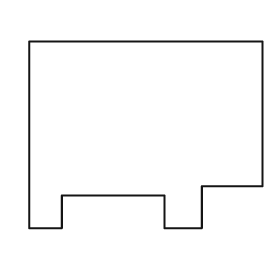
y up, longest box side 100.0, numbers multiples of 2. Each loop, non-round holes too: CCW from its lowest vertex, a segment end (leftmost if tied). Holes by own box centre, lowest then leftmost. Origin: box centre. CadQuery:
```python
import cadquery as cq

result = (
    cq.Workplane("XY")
    .moveTo(-50.0, -40.0)
    .lineTo(-36.0, -40.0)
    .lineTo(-36.0, -26.0)
    .lineTo(8.0, -26.0)
    .lineTo(8.0, -40.0)
    .lineTo(24.0, -40.0)
    .lineTo(24.0, -22.0)
    .lineTo(50.0, -22.0)
    .lineTo(50.0, 40.0)
    .lineTo(-50.0, 40.0)
    .close()
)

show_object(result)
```